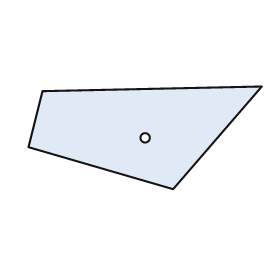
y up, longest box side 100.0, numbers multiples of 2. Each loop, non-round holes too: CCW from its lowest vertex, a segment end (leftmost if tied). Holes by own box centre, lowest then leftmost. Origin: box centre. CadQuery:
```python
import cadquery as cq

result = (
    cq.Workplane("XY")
    .moveTo(12.0, -22.0)
    .lineTo(50.0, 22.0)
    .lineTo(-44.0, 20.0)
    .lineTo(-50.0, -4.0)
    .close()
    .moveTo(0.0, 0.0)
    .circle(2.0)
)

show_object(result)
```